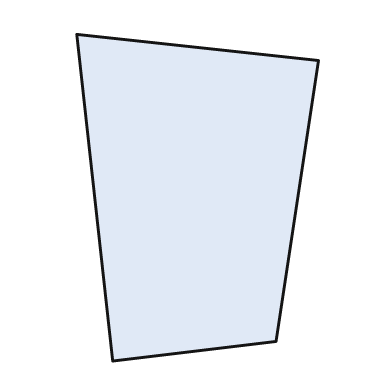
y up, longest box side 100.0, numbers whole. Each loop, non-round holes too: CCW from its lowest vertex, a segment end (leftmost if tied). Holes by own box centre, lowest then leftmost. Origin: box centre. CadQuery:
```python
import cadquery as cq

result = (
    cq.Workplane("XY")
    .moveTo(-26.0, -50.0)
    .lineTo(24.0, -44.0)
    .lineTo(37.0, 42.0)
    .lineTo(-37.0, 50.0)
    .close()
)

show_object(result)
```